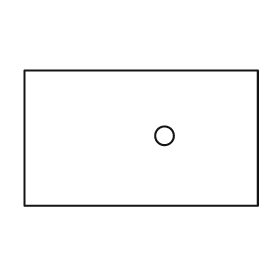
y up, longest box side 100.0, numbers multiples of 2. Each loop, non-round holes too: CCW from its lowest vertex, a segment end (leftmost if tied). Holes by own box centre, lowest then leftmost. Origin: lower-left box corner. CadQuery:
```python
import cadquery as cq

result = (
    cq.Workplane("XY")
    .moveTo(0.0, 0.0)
    .lineTo(100.0, 0.0)
    .lineTo(100.0, 58.0)
    .lineTo(0.0, 58.0)
    .close()
    .moveTo(60.0, 30.0)
    .circle(4.0)
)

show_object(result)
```